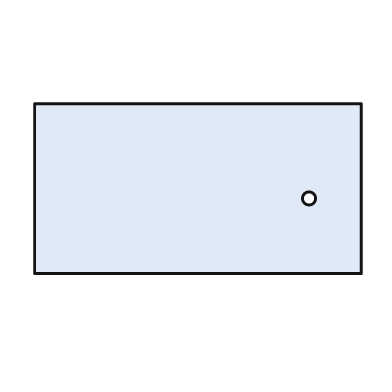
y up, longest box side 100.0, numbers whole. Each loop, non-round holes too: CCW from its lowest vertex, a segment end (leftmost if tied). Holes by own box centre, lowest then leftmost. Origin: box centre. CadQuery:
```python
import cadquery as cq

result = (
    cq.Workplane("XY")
    .moveTo(-50.0, -26.0)
    .lineTo(50.0, -26.0)
    .lineTo(50.0, 26.0)
    .lineTo(-50.0, 26.0)
    .close()
    .moveTo(34.0, -3.0)
    .circle(2.0)
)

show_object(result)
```